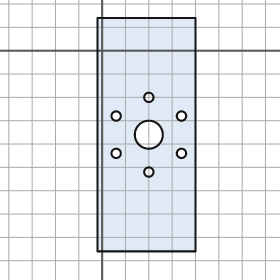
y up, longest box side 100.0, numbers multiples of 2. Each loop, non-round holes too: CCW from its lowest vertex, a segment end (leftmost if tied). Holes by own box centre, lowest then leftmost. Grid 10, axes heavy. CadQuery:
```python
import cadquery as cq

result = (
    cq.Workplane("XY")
    .moveTo(-2.0, -86.0)
    .lineTo(40.0, -86.0)
    .lineTo(40.0, 14.0)
    .lineTo(-2.0, 14.0)
    .close()
    .moveTo(20.0, -52.0)
    .circle(2.0)
    .moveTo(6.0, -44.0)
    .circle(2.0)
    .moveTo(34.0, -44.0)
    .circle(2.0)
    .moveTo(20.0, -36.0)
    .circle(6.0)
    .moveTo(6.0, -28.0)
    .circle(2.0)
    .moveTo(34.0, -28.0)
    .circle(2.0)
    .moveTo(20.0, -20.0)
    .circle(2.0)
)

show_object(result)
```